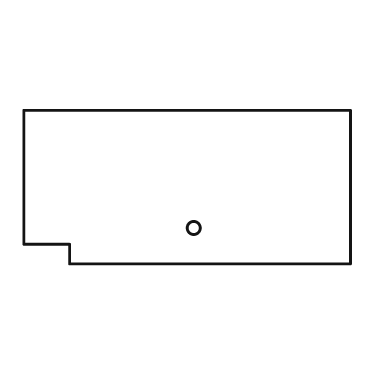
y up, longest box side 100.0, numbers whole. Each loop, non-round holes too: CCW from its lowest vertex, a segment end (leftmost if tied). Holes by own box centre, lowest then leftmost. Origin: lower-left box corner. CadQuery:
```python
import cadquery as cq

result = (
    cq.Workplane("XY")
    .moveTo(14.0, 0.0)
    .lineTo(100.0, 0.0)
    .lineTo(100.0, 47.0)
    .lineTo(0.0, 47.0)
    .lineTo(0.0, 6.0)
    .lineTo(14.0, 6.0)
    .close()
    .moveTo(52.0, 11.0)
    .circle(2.0)
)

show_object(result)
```